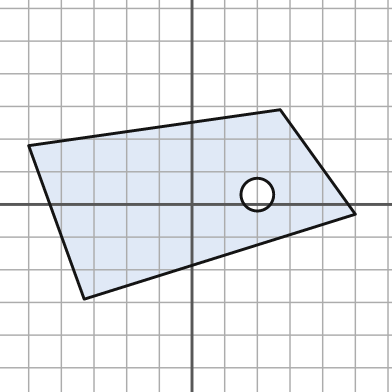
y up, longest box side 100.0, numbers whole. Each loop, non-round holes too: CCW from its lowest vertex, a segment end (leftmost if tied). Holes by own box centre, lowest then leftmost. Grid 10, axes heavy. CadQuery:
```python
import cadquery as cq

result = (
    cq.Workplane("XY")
    .moveTo(-33.0, -29.0)
    .lineTo(50.0, -3.0)
    .lineTo(27.0, 29.0)
    .lineTo(-50.0, 18.0)
    .close()
    .moveTo(20.0, 3.0)
    .circle(5.0)
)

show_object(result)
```